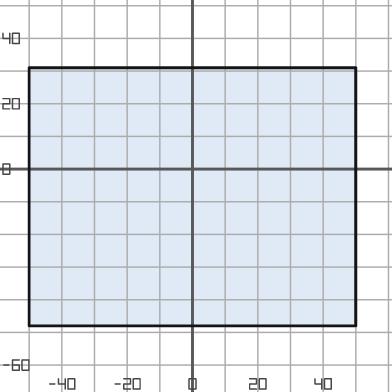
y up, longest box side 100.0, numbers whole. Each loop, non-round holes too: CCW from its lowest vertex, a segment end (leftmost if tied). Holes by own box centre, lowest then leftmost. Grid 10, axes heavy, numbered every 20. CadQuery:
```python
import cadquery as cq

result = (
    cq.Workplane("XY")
    .moveTo(-50.0, -48.0)
    .lineTo(50.0, -48.0)
    .lineTo(50.0, 31.0)
    .lineTo(-50.0, 31.0)
    .close()
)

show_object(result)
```